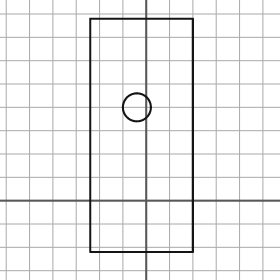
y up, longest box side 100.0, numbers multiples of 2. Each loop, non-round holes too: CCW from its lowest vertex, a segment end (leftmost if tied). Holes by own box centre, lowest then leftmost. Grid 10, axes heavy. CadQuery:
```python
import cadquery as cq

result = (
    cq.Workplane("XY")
    .moveTo(-24.0, -22.0)
    .lineTo(20.0, -22.0)
    .lineTo(20.0, 78.0)
    .lineTo(-24.0, 78.0)
    .close()
    .moveTo(-4.0, 40.0)
    .circle(6.0)
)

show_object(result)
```